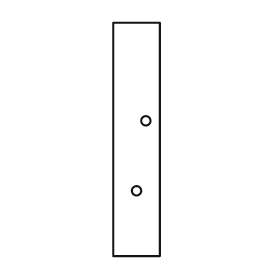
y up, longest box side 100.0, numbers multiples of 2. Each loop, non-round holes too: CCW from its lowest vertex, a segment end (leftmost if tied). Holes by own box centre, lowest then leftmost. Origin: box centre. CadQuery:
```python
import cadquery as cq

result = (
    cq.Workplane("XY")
    .moveTo(-10.0, -50.0)
    .lineTo(10.0, -50.0)
    .lineTo(10.0, 50.0)
    .lineTo(-10.0, 50.0)
    .close()
    .moveTo(0.0, -22.0)
    .circle(2.0)
    .moveTo(4.0, 8.0)
    .circle(2.0)
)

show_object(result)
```